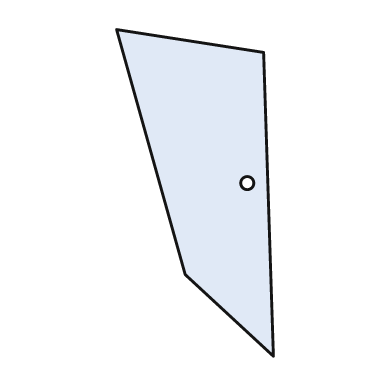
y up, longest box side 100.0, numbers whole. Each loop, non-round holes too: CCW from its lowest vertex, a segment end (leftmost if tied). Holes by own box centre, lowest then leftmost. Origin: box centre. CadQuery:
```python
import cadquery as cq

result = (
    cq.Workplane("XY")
    .moveTo(24.0, -50.0)
    .lineTo(21.0, 43.0)
    .lineTo(-24.0, 50.0)
    .lineTo(-3.0, -25.0)
    .close()
    .moveTo(16.0, 3.0)
    .circle(2.0)
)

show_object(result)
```